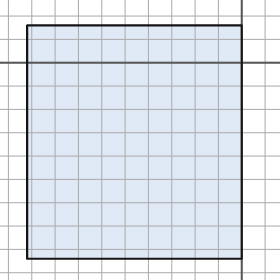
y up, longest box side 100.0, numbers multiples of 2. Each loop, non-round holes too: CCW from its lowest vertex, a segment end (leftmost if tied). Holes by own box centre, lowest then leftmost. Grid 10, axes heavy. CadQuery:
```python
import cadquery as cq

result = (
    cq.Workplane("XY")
    .moveTo(-92.0, -84.0)
    .lineTo(0.0, -84.0)
    .lineTo(0.0, 16.0)
    .lineTo(-92.0, 16.0)
    .close()
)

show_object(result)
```